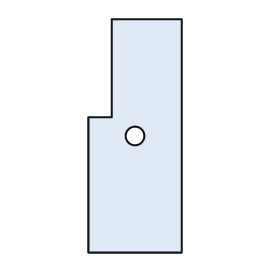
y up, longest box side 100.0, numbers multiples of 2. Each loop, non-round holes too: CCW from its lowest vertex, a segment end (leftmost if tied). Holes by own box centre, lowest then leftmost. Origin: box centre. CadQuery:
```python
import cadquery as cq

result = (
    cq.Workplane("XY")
    .moveTo(-20.0, -50.0)
    .lineTo(20.0, -50.0)
    .lineTo(20.0, 50.0)
    .lineTo(-10.0, 50.0)
    .lineTo(-10.0, 8.0)
    .lineTo(-20.0, 8.0)
    .close()
    .moveTo(0.0, 0.0)
    .circle(4.0)
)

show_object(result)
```